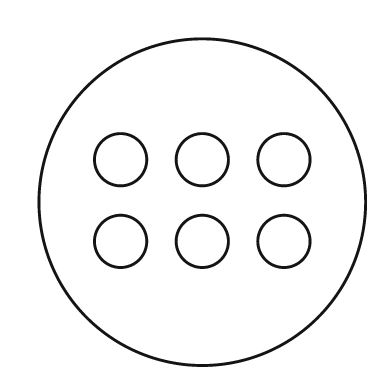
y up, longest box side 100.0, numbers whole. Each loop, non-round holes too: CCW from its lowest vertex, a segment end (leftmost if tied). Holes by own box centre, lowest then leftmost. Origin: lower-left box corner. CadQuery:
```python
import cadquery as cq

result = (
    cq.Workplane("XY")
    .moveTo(50.0, 50.0)
    .circle(50.0)
    .moveTo(25.0, 38.0)
    .circle(8.0)
    .moveTo(50.0, 38.0)
    .circle(8.0)
    .moveTo(75.0, 38.0)
    .circle(8.0)
    .moveTo(25.0, 63.0)
    .circle(8.0)
    .moveTo(50.0, 63.0)
    .circle(8.0)
    .moveTo(75.0, 63.0)
    .circle(8.0)
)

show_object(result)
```